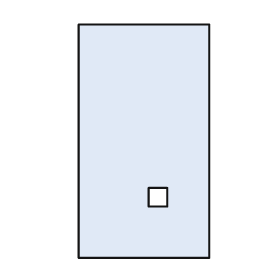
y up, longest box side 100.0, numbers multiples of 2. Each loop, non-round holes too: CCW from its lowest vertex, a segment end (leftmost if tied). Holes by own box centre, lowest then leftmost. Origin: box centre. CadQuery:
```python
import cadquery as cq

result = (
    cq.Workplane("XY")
    .moveTo(-28.0, -50.0)
    .lineTo(28.0, -50.0)
    .lineTo(28.0, 50.0)
    .lineTo(-28.0, 50.0)
    .close()
    .moveTo(2.0, -28.0)
    .lineTo(10.0, -28.0)
    .lineTo(10.0, -20.0)
    .lineTo(2.0, -20.0)
    .close()
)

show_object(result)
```